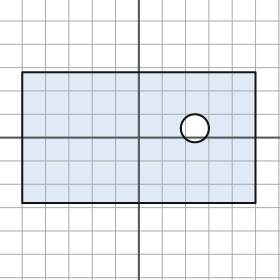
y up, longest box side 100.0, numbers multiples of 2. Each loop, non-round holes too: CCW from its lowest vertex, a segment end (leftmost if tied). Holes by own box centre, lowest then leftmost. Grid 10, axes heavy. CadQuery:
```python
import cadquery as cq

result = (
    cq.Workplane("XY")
    .moveTo(-50.0, -28.0)
    .lineTo(50.0, -28.0)
    .lineTo(50.0, 28.0)
    .lineTo(-50.0, 28.0)
    .close()
    .moveTo(24.0, 4.0)
    .circle(6.0)
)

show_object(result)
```